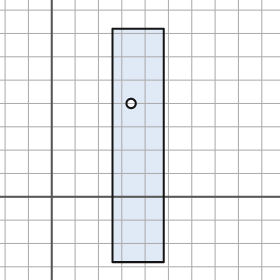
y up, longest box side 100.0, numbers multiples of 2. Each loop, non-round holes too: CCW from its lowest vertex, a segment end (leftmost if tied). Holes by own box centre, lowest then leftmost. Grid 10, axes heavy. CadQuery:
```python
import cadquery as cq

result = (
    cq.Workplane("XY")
    .moveTo(26.0, -28.0)
    .lineTo(48.0, -28.0)
    .lineTo(48.0, 72.0)
    .lineTo(26.0, 72.0)
    .close()
    .moveTo(34.0, 40.0)
    .circle(2.0)
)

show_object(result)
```